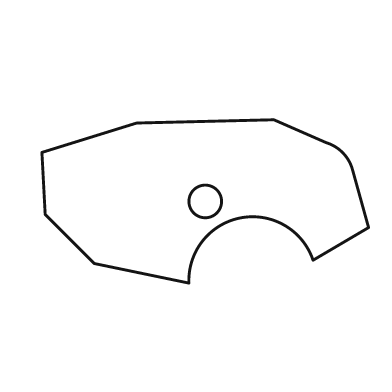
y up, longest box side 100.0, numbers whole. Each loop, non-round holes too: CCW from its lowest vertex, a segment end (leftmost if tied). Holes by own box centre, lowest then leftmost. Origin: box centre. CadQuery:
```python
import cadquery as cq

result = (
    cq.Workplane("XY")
    .moveTo(-5.0, -25.0)
    .threePointArc((11.0, -5.0), (33.0, -18.0))
    .lineTo(50.0, -8.0)
    .lineTo(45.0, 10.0)
    .threePointArc((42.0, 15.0), (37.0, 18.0))
    .lineTo(21.0, 25.0)
    .lineTo(-21.0, 24.0)
    .lineTo(-50.0, 15.0)
    .lineTo(-49.0, -4.0)
    .lineTo(-34.0, -19.0)
    .close()
    .moveTo(0.0, 0.0)
    .circle(5.0)
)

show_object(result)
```